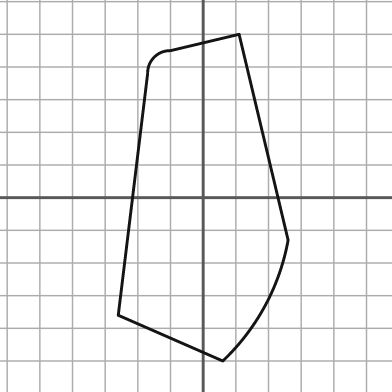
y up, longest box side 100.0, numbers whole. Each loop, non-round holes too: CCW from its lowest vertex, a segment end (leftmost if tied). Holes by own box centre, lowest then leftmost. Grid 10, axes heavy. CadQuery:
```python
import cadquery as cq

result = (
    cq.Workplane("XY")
    .moveTo(6.0, -50.0)
    .threePointArc((19.0, -33.0), (26.0, -13.0))
    .lineTo(11.0, 50.0)
    .lineTo(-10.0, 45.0)
    .threePointArc((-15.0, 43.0), (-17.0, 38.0))
    .lineTo(-26.0, -36.0)
    .close()
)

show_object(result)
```